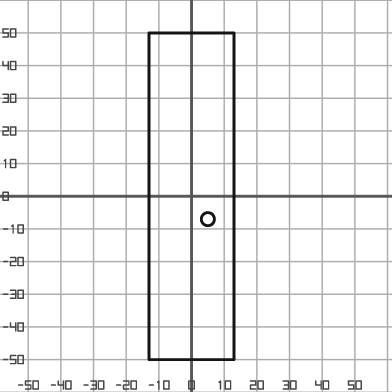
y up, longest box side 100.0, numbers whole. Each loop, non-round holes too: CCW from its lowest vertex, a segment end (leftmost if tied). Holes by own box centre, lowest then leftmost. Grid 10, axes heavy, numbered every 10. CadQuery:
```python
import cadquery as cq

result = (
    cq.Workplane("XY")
    .moveTo(-13.0, -50.0)
    .lineTo(13.0, -50.0)
    .lineTo(13.0, 50.0)
    .lineTo(-13.0, 50.0)
    .close()
    .moveTo(5.0, -7.0)
    .circle(2.0)
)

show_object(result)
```